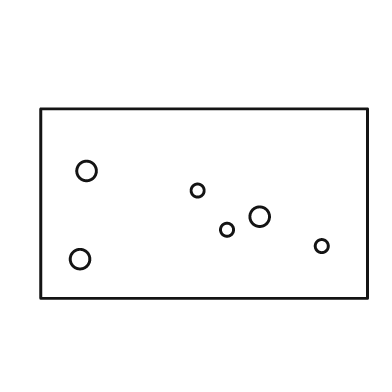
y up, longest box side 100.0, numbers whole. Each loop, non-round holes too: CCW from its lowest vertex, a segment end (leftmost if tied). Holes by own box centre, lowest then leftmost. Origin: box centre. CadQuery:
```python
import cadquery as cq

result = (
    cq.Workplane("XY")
    .moveTo(-50.0, -29.0)
    .lineTo(50.0, -29.0)
    .lineTo(50.0, 29.0)
    .lineTo(-50.0, 29.0)
    .close()
    .moveTo(-38.0, -17.0)
    .circle(3.0)
    .moveTo(36.0, -13.0)
    .circle(2.0)
    .moveTo(7.0, -8.0)
    .circle(2.0)
    .moveTo(17.0, -4.0)
    .circle(3.0)
    .moveTo(-2.0, 4.0)
    .circle(2.0)
    .moveTo(-36.0, 10.0)
    .circle(3.0)
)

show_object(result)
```